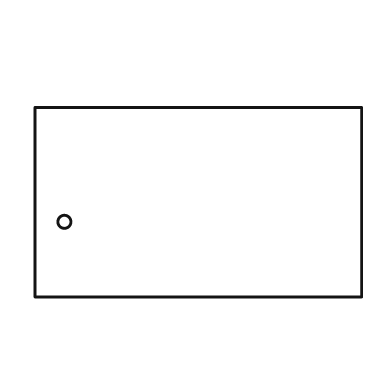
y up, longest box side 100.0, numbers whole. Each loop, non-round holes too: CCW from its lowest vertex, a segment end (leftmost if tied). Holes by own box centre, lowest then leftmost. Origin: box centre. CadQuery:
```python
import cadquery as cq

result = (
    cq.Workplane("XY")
    .moveTo(-50.0, -29.0)
    .lineTo(50.0, -29.0)
    .lineTo(50.0, 29.0)
    .lineTo(-50.0, 29.0)
    .close()
    .moveTo(-41.0, -6.0)
    .circle(2.0)
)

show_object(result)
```